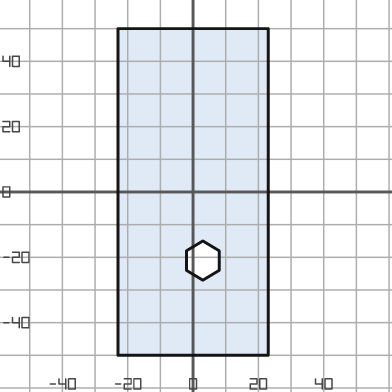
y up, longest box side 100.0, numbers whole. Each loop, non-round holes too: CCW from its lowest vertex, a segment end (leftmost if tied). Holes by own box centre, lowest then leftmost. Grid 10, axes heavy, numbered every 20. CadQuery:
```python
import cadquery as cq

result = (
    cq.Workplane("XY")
    .moveTo(-23.0, -50.0)
    .lineTo(23.0, -50.0)
    .lineTo(23.0, 50.0)
    .lineTo(-23.0, 50.0)
    .close()
    .moveTo(3.0, -27.0)
    .lineTo(8.0, -24.0)
    .lineTo(8.0, -18.0)
    .lineTo(3.0, -15.0)
    .lineTo(-2.0, -18.0)
    .lineTo(-2.0, -24.0)
    .close()
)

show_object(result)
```